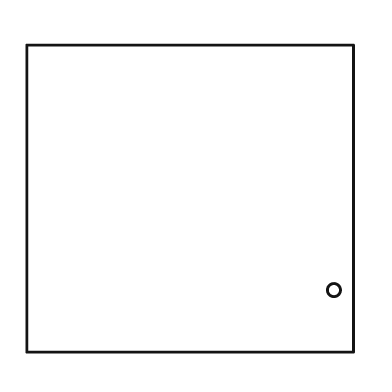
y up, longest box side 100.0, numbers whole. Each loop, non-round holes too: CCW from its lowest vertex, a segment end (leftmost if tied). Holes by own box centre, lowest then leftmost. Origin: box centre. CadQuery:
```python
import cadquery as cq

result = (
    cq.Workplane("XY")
    .moveTo(-50.0, -47.0)
    .lineTo(50.0, -47.0)
    .lineTo(50.0, 47.0)
    .lineTo(-50.0, 47.0)
    .close()
    .moveTo(44.0, -28.0)
    .circle(2.0)
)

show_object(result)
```